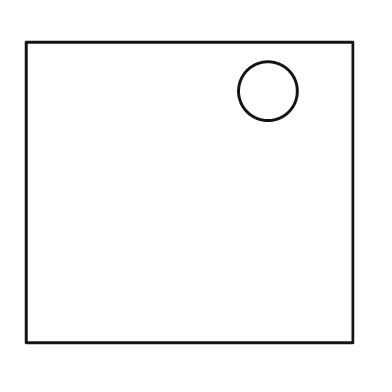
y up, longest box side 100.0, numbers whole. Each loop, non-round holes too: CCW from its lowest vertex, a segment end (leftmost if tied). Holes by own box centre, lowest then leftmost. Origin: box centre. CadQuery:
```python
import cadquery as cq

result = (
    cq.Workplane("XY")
    .moveTo(-50.0, -46.0)
    .lineTo(50.0, -46.0)
    .lineTo(50.0, 46.0)
    .lineTo(-50.0, 46.0)
    .close()
    .moveTo(24.0, 31.0)
    .circle(9.0)
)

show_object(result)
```